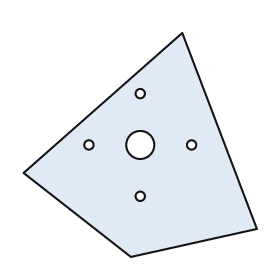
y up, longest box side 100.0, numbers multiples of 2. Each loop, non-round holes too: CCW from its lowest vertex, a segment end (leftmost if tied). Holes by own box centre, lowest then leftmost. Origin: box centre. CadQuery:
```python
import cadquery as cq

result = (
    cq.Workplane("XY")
    .moveTo(-4.0, -48.0)
    .lineTo(50.0, -36.0)
    .lineTo(18.0, 48.0)
    .lineTo(-50.0, -12.0)
    .close()
    .moveTo(0.0, -22.0)
    .circle(2.0)
    .moveTo(-22.0, 0.0)
    .circle(2.0)
    .moveTo(0.0, 0.0)
    .circle(6.0)
    .moveTo(22.0, 0.0)
    .circle(2.0)
    .moveTo(0.0, 22.0)
    .circle(2.0)
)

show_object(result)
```